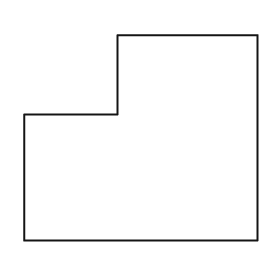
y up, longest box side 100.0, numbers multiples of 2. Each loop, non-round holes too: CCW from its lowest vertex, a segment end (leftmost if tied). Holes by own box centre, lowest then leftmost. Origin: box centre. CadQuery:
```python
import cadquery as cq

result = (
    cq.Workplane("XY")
    .moveTo(-50.0, -44.0)
    .lineTo(50.0, -44.0)
    .lineTo(50.0, 44.0)
    .lineTo(-10.0, 44.0)
    .lineTo(-10.0, 10.0)
    .lineTo(-50.0, 10.0)
    .close()
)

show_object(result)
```